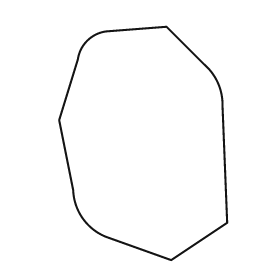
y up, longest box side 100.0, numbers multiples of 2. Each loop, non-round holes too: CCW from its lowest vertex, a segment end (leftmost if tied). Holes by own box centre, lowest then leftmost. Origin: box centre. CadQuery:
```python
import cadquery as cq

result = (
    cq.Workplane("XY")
    .moveTo(12.0, -50.0)
    .lineTo(36.0, -34.0)
    .lineTo(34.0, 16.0)
    .threePointArc((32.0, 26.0), (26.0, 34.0))
    .lineTo(10.0, 50.0)
    .lineTo(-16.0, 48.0)
    .threePointArc((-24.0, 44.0), (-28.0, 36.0))
    .lineTo(-36.0, 10.0)
    .lineTo(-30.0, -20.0)
    .threePointArc((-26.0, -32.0), (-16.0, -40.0))
    .close()
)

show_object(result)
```